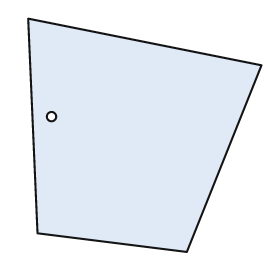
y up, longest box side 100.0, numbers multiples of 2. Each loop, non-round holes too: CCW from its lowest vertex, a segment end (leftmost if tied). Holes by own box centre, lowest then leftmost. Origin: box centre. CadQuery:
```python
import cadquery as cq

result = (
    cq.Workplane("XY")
    .moveTo(18.0, -50.0)
    .lineTo(50.0, 30.0)
    .lineTo(-50.0, 50.0)
    .lineTo(-46.0, -42.0)
    .close()
    .moveTo(-40.0, 8.0)
    .circle(2.0)
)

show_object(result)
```